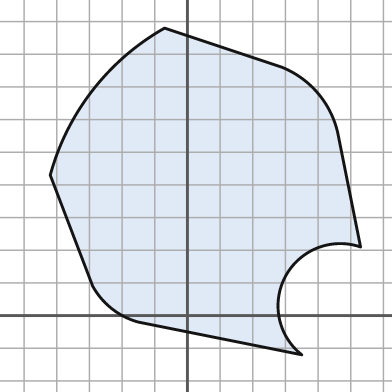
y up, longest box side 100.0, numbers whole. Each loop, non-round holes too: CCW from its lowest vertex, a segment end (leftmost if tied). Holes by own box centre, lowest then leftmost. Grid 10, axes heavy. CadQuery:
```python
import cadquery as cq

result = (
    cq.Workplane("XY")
    .moveTo(35.0, -12.0)
    .threePointArc((30.0, 12.0), (53.0, 21.0))
    .lineTo(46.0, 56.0)
    .threePointArc((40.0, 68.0), (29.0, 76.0))
    .lineTo(-7.0, 88.0)
    .threePointArc((-29.0, 69.0), (-42.0, 43.0))
    .lineTo(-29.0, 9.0)
    .threePointArc((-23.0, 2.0), (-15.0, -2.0))
    .close()
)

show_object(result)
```